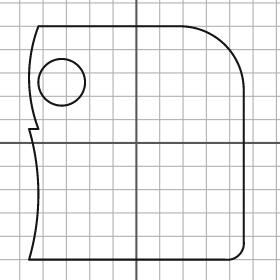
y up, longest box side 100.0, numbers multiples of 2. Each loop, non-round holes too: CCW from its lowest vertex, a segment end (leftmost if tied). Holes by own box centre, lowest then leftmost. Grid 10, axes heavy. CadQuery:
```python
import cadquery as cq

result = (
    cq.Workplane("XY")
    .moveTo(-46.0, -50.0)
    .lineTo(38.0, -50.0)
    .threePointArc((44.0, -48.0), (46.0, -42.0))
    .lineTo(46.0, 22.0)
    .threePointArc((38.0, 42.0), (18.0, 50.0))
    .lineTo(-42.0, 50.0)
    .threePointArc((-46.0, 28.0), (-42.0, 6.0))
    .lineTo(-46.0, 6.0)
    .threePointArc((-42.0, -22.0), (-46.0, -50.0))
    .close()
    .moveTo(-32.0, 26.0)
    .circle(10.0)
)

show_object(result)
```